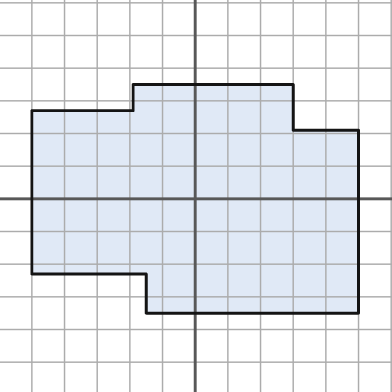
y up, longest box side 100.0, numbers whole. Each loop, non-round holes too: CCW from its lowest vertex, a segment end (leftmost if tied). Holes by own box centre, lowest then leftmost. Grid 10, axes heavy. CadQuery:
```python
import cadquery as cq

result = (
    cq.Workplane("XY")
    .moveTo(-15.0, -35.0)
    .lineTo(50.0, -35.0)
    .lineTo(50.0, 21.0)
    .lineTo(30.0, 21.0)
    .lineTo(30.0, 35.0)
    .lineTo(-19.0, 35.0)
    .lineTo(-19.0, 27.0)
    .lineTo(-50.0, 27.0)
    .lineTo(-50.0, -23.0)
    .lineTo(-15.0, -23.0)
    .close()
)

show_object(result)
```